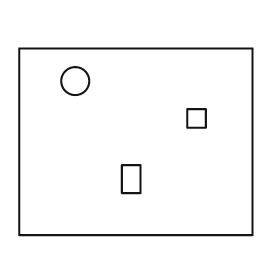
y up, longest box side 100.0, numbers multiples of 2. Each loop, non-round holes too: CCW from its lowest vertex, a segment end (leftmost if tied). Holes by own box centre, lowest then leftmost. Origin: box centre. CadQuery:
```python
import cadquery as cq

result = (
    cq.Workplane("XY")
    .moveTo(-50.0, -40.0)
    .lineTo(50.0, -40.0)
    .lineTo(50.0, 40.0)
    .lineTo(-50.0, 40.0)
    .close()
    .moveTo(-6.0, -22.0)
    .lineTo(2.0, -22.0)
    .lineTo(2.0, -10.0)
    .lineTo(-6.0, -10.0)
    .close()
    .moveTo(22.0, 6.0)
    .lineTo(30.0, 6.0)
    .lineTo(30.0, 14.0)
    .lineTo(22.0, 14.0)
    .close()
    .moveTo(-26.0, 26.0)
    .circle(6.0)
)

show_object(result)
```